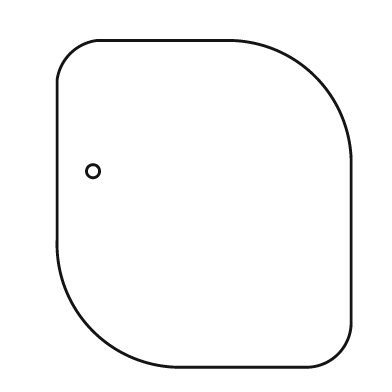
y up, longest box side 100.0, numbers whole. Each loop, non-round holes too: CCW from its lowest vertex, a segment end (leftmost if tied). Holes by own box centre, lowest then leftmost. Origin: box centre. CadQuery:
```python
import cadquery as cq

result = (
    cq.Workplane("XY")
    .moveTo(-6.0, -50.0)
    .lineTo(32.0, -50.0)
    .threePointArc((41.0, -46.0), (45.0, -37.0))
    .lineTo(45.0, 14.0)
    .threePointArc((34.0, 39.0), (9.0, 50.0))
    .lineTo(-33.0, 50.0)
    .threePointArc((-41.0, 46.0), (-45.0, 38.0))
    .lineTo(-45.0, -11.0)
    .threePointArc((-34.0, -39.0), (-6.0, -50.0))
    .close()
    .moveTo(-34.0, 10.0)
    .circle(2.0)
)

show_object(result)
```